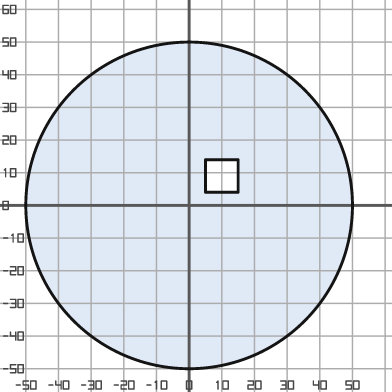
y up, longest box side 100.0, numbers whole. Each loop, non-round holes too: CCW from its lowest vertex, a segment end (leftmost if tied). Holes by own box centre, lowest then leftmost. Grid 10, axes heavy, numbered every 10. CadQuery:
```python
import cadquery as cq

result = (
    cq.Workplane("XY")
    .moveTo(0.0, 0.0)
    .circle(50.0)
    .moveTo(5.0, 4.0)
    .lineTo(15.0, 4.0)
    .lineTo(15.0, 14.0)
    .lineTo(5.0, 14.0)
    .close()
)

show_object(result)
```